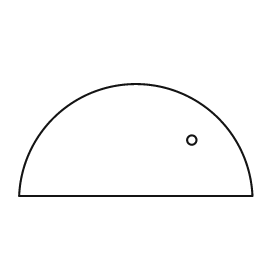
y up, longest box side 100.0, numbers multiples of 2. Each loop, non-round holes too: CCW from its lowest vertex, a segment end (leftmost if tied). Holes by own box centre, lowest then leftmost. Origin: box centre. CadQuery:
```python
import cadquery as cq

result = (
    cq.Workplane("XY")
    .moveTo(-50.0, -24.0)
    .lineTo(50.0, -24.0)
    .threePointArc((0.0, 24.0), (-50.0, -24.0))
    .close()
    .moveTo(24.0, 0.0)
    .circle(2.0)
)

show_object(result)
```